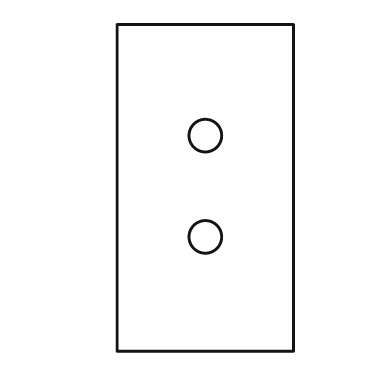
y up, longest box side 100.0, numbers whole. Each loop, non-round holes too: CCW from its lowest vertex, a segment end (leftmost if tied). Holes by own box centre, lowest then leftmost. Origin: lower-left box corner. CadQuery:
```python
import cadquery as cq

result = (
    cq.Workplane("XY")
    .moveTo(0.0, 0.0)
    .lineTo(54.0, 0.0)
    .lineTo(54.0, 100.0)
    .lineTo(0.0, 100.0)
    .close()
    .moveTo(27.0, 35.0)
    .circle(5.0)
    .moveTo(27.0, 66.0)
    .circle(5.0)
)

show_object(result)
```